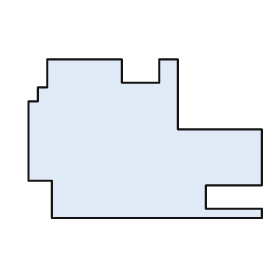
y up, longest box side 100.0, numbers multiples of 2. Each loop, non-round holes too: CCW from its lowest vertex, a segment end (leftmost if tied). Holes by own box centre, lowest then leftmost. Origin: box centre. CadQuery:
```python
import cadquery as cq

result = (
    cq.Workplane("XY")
    .moveTo(-40.0, -34.0)
    .lineTo(50.0, -34.0)
    .lineTo(50.0, -30.0)
    .lineTo(26.0, -30.0)
    .lineTo(26.0, -20.0)
    .lineTo(50.0, -20.0)
    .lineTo(50.0, 4.0)
    .lineTo(14.0, 4.0)
    .lineTo(14.0, 34.0)
    .lineTo(6.0, 34.0)
    .lineTo(6.0, 24.0)
    .lineTo(-10.0, 24.0)
    .lineTo(-10.0, 34.0)
    .lineTo(-42.0, 34.0)
    .lineTo(-42.0, 22.0)
    .lineTo(-46.0, 22.0)
    .lineTo(-46.0, 16.0)
    .lineTo(-50.0, 16.0)
    .lineTo(-50.0, -18.0)
    .lineTo(-40.0, -18.0)
    .close()
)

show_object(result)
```